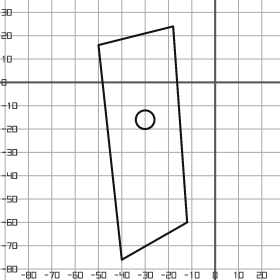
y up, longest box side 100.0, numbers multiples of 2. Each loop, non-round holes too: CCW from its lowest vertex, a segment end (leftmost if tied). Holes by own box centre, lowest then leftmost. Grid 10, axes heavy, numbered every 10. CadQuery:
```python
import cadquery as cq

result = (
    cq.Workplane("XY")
    .moveTo(-40.0, -76.0)
    .lineTo(-12.0, -60.0)
    .lineTo(-18.0, 24.0)
    .lineTo(-50.0, 16.0)
    .close()
    .moveTo(-30.0, -16.0)
    .circle(4.0)
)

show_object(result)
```